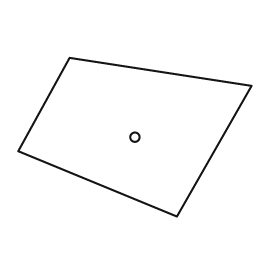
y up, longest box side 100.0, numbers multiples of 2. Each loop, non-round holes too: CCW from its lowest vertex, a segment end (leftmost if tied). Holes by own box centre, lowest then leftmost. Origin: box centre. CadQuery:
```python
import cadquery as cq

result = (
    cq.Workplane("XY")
    .moveTo(18.0, -34.0)
    .lineTo(50.0, 22.0)
    .lineTo(-28.0, 34.0)
    .lineTo(-50.0, -6.0)
    .close()
    .moveTo(0.0, 0.0)
    .circle(2.0)
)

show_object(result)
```